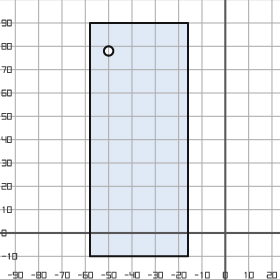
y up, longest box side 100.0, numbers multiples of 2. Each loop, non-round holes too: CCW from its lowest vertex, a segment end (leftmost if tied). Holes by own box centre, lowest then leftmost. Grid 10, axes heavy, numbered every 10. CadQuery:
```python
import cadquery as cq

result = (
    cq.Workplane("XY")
    .moveTo(-58.0, -10.0)
    .lineTo(-16.0, -10.0)
    .lineTo(-16.0, 90.0)
    .lineTo(-58.0, 90.0)
    .close()
    .moveTo(-50.0, 78.0)
    .circle(2.0)
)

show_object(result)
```